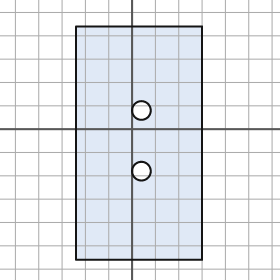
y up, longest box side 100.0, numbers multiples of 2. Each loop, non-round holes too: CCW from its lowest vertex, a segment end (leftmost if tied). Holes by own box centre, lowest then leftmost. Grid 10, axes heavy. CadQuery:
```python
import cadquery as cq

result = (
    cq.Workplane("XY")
    .moveTo(-24.0, -56.0)
    .lineTo(30.0, -56.0)
    .lineTo(30.0, 44.0)
    .lineTo(-24.0, 44.0)
    .close()
    .moveTo(4.0, -18.0)
    .circle(4.0)
    .moveTo(4.0, 8.0)
    .circle(4.0)
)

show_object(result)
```